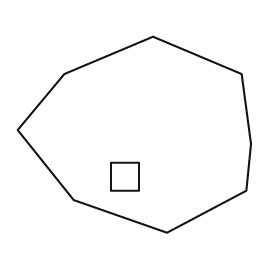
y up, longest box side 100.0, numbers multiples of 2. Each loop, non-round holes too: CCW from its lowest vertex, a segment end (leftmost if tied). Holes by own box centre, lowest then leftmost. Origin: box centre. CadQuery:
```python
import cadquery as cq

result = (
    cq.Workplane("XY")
    .moveTo(14.0, -42.0)
    .lineTo(48.0, -24.0)
    .lineTo(50.0, -4.0)
    .lineTo(46.0, 26.0)
    .lineTo(8.0, 42.0)
    .lineTo(-30.0, 26.0)
    .lineTo(-50.0, 2.0)
    .lineTo(-26.0, -28.0)
    .close()
    .moveTo(-10.0, -24.0)
    .lineTo(2.0, -24.0)
    .lineTo(2.0, -12.0)
    .lineTo(-10.0, -12.0)
    .close()
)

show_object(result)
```